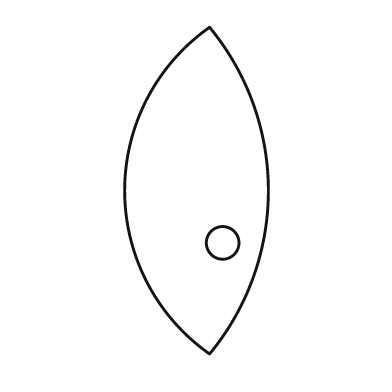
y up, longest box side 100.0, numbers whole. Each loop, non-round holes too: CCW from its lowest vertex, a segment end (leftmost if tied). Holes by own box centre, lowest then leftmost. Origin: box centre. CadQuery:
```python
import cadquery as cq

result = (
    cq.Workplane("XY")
    .moveTo(4.0, -50.0)
    .threePointArc((22.0, 0.0), (4.0, 50.0))
    .threePointArc((-22.0, 0.0), (4.0, -50.0))
    .close()
    .moveTo(8.0, -16.0)
    .circle(5.0)
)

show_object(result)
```